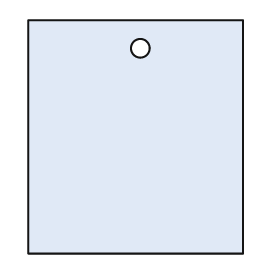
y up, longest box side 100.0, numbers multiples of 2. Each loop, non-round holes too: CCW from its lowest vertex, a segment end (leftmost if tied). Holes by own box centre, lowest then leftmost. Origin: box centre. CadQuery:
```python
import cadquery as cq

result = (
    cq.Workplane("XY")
    .moveTo(-46.0, -50.0)
    .lineTo(46.0, -50.0)
    .lineTo(46.0, 50.0)
    .lineTo(-46.0, 50.0)
    .close()
    .moveTo(2.0, 38.0)
    .circle(4.0)
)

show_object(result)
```